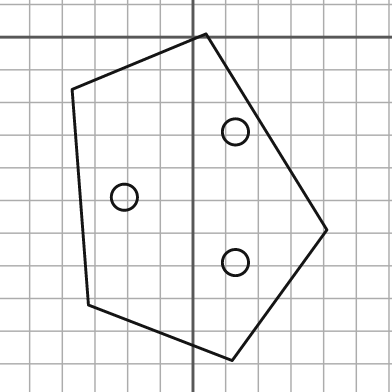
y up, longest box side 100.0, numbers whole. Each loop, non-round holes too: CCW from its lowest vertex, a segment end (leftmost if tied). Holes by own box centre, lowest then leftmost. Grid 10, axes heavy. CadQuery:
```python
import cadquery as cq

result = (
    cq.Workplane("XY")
    .moveTo(12.0, -99.0)
    .lineTo(41.0, -59.0)
    .lineTo(4.0, 1.0)
    .lineTo(-37.0, -16.0)
    .lineTo(-32.0, -82.0)
    .close()
    .moveTo(13.0, -69.0)
    .circle(4.0)
    .moveTo(-21.0, -49.0)
    .circle(4.0)
    .moveTo(13.0, -29.0)
    .circle(4.0)
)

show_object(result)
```